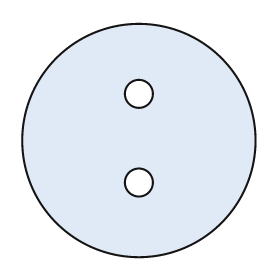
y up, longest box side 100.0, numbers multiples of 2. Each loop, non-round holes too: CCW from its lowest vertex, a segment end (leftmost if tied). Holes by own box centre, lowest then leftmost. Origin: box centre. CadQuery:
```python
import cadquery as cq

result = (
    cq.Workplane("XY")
    .moveTo(0.0, 0.0)
    .circle(50.0)
    .moveTo(0.0, -18.0)
    .circle(6.0)
    .moveTo(0.0, 20.0)
    .circle(6.0)
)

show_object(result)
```